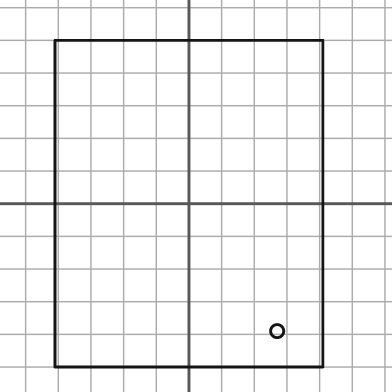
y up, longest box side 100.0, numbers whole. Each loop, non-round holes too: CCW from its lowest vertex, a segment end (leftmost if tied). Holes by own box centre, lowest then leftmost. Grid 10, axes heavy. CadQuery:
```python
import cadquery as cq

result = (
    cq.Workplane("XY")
    .moveTo(-41.0, -50.0)
    .lineTo(41.0, -50.0)
    .lineTo(41.0, 50.0)
    .lineTo(-41.0, 50.0)
    .close()
    .moveTo(27.0, -39.0)
    .circle(2.0)
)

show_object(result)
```